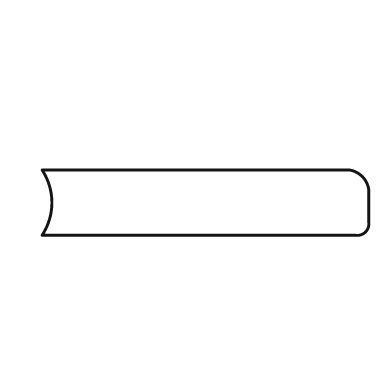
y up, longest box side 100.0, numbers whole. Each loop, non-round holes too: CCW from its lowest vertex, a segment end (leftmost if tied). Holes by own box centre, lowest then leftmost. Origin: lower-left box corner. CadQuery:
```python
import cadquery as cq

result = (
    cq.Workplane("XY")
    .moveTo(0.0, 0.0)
    .lineTo(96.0, 0.0)
    .threePointArc((99.0, 1.0), (100.0, 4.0))
    .lineTo(100.0, 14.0)
    .threePointArc((98.0, 18.0), (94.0, 20.0))
    .lineTo(0.0, 20.0)
    .threePointArc((3.0, 10.0), (0.0, 0.0))
    .close()
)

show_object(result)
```